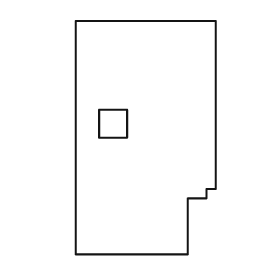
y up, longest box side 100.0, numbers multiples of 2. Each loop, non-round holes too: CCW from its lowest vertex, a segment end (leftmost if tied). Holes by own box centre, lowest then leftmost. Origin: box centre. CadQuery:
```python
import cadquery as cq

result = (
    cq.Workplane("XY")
    .moveTo(-30.0, -50.0)
    .lineTo(18.0, -50.0)
    .lineTo(18.0, -26.0)
    .lineTo(26.0, -26.0)
    .lineTo(26.0, -22.0)
    .lineTo(30.0, -22.0)
    .lineTo(30.0, 50.0)
    .lineTo(-30.0, 50.0)
    .close()
    .moveTo(-20.0, 0.0)
    .lineTo(-8.0, 0.0)
    .lineTo(-8.0, 12.0)
    .lineTo(-20.0, 12.0)
    .close()
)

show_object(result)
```